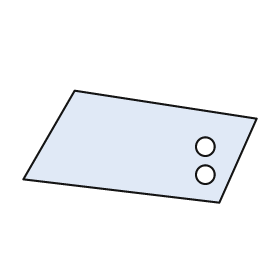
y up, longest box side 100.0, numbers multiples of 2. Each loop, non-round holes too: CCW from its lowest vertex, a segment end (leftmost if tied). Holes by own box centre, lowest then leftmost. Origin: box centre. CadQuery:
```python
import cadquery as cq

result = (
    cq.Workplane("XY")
    .moveTo(34.0, -24.0)
    .lineTo(50.0, 12.0)
    .lineTo(-28.0, 24.0)
    .lineTo(-50.0, -14.0)
    .close()
    .moveTo(28.0, -12.0)
    .circle(4.0)
    .moveTo(28.0, 0.0)
    .circle(4.0)
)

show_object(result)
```